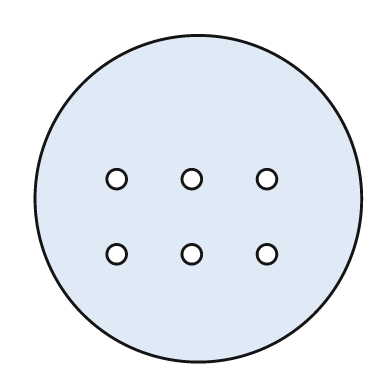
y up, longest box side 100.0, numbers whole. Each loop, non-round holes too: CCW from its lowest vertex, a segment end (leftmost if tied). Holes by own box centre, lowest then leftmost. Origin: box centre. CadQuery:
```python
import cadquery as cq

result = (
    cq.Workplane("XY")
    .moveTo(0.0, 0.0)
    .circle(50.0)
    .moveTo(-25.0, -17.0)
    .circle(3.0)
    .moveTo(-2.0, -17.0)
    .circle(3.0)
    .moveTo(21.0, -17.0)
    .circle(3.0)
    .moveTo(-25.0, 6.0)
    .circle(3.0)
    .moveTo(-2.0, 6.0)
    .circle(3.0)
    .moveTo(21.0, 6.0)
    .circle(3.0)
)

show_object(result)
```